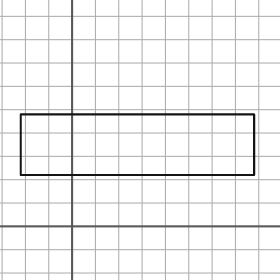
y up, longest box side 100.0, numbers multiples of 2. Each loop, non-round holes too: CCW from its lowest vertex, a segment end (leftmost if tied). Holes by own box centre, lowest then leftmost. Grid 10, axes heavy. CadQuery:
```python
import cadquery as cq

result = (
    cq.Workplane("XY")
    .moveTo(-22.0, 22.0)
    .lineTo(78.0, 22.0)
    .lineTo(78.0, 48.0)
    .lineTo(-22.0, 48.0)
    .close()
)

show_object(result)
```